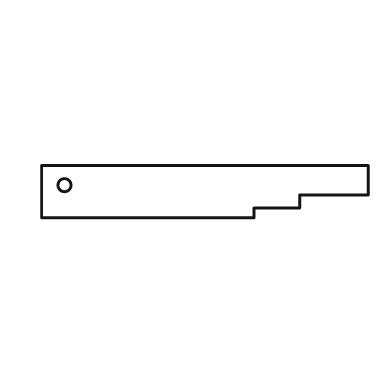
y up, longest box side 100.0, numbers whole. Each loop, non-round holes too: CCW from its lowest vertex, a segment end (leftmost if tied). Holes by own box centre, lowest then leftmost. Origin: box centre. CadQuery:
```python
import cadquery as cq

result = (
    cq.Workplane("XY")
    .moveTo(-50.0, -8.0)
    .lineTo(15.0, -8.0)
    .lineTo(15.0, -5.0)
    .lineTo(29.0, -5.0)
    .lineTo(29.0, -1.0)
    .lineTo(50.0, -1.0)
    .lineTo(50.0, 8.0)
    .lineTo(-50.0, 8.0)
    .close()
    .moveTo(-43.0, 2.0)
    .circle(2.0)
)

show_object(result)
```